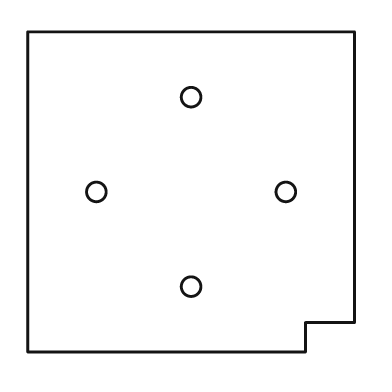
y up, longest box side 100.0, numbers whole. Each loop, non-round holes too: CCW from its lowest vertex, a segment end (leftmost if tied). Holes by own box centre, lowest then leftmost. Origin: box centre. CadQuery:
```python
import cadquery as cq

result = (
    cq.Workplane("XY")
    .moveTo(-50.0, -49.0)
    .lineTo(35.0, -49.0)
    .lineTo(35.0, -40.0)
    .lineTo(50.0, -40.0)
    .lineTo(50.0, 49.0)
    .lineTo(-50.0, 49.0)
    .close()
    .moveTo(0.0, -29.0)
    .circle(3.0)
    .moveTo(-29.0, 0.0)
    .circle(3.0)
    .moveTo(29.0, 0.0)
    .circle(3.0)
    .moveTo(0.0, 29.0)
    .circle(3.0)
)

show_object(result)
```